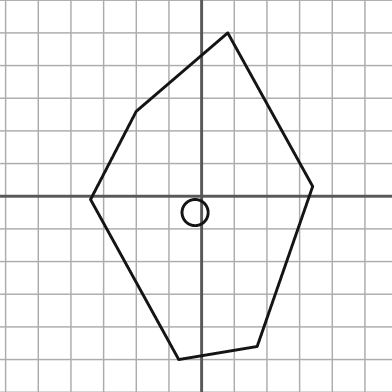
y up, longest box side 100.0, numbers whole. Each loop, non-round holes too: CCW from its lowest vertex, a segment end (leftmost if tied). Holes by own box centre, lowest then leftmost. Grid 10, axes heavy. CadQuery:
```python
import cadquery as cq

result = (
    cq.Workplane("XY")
    .moveTo(-7.0, -50.0)
    .lineTo(17.0, -46.0)
    .lineTo(34.0, 3.0)
    .lineTo(8.0, 50.0)
    .lineTo(-20.0, 26.0)
    .lineTo(-34.0, -1.0)
    .close()
    .moveTo(-2.0, -5.0)
    .circle(4.0)
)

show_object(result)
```